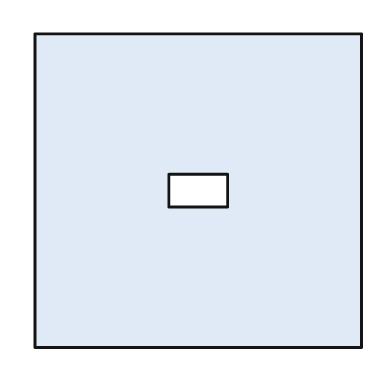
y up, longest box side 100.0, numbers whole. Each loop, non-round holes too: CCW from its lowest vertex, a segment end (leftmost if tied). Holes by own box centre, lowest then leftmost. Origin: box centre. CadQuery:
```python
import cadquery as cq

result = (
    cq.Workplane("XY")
    .moveTo(-50.0, -48.0)
    .lineTo(50.0, -48.0)
    .lineTo(50.0, 48.0)
    .lineTo(-50.0, 48.0)
    .close()
    .moveTo(-9.0, -5.0)
    .lineTo(9.0, -5.0)
    .lineTo(9.0, 5.0)
    .lineTo(-9.0, 5.0)
    .close()
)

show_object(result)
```